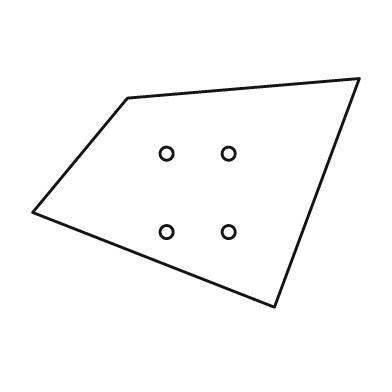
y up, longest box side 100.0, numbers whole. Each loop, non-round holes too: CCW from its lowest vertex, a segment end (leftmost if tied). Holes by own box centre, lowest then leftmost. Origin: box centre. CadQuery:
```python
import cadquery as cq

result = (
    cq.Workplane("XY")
    .moveTo(24.0, -35.0)
    .lineTo(50.0, 35.0)
    .lineTo(-21.0, 29.0)
    .lineTo(-50.0, -6.0)
    .close()
    .moveTo(-9.0, -12.0)
    .circle(2.0)
    .moveTo(10.0, -12.0)
    .circle(2.0)
    .moveTo(-9.0, 12.0)
    .circle(2.0)
    .moveTo(10.0, 12.0)
    .circle(2.0)
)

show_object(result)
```